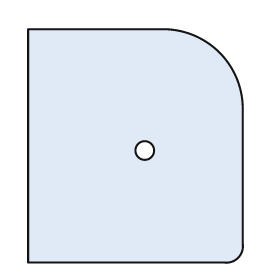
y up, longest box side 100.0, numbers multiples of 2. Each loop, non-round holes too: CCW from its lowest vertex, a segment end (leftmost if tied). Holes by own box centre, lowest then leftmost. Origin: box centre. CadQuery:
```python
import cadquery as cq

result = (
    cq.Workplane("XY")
    .moveTo(-46.0, -50.0)
    .lineTo(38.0, -50.0)
    .threePointArc((44.0, -48.0), (46.0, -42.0))
    .lineTo(46.0, 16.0)
    .threePointArc((36.0, 40.0), (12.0, 50.0))
    .lineTo(-46.0, 50.0)
    .close()
    .moveTo(4.0, -2.0)
    .circle(4.0)
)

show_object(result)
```